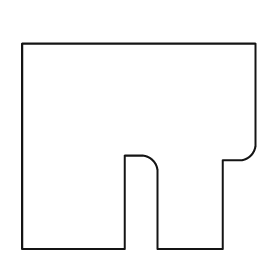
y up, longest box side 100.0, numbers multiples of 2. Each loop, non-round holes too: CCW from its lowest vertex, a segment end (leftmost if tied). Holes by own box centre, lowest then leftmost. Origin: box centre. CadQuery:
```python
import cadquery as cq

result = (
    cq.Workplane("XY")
    .moveTo(-50.0, -44.0)
    .lineTo(-6.0, -44.0)
    .lineTo(-6.0, -4.0)
    .lineTo(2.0, -4.0)
    .threePointArc((6.0, -6.0), (8.0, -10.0))
    .lineTo(8.0, -44.0)
    .lineTo(36.0, -44.0)
    .lineTo(36.0, -6.0)
    .lineTo(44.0, -6.0)
    .threePointArc((48.0, -4.0), (50.0, 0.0))
    .lineTo(50.0, 44.0)
    .lineTo(-50.0, 44.0)
    .close()
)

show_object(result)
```